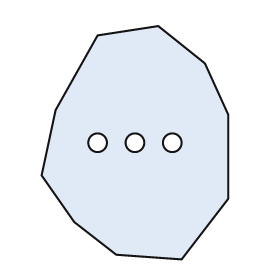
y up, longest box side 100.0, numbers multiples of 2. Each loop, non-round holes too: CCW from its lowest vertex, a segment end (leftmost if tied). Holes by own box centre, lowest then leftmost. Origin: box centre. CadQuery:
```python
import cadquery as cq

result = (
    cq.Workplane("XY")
    .moveTo(20.0, -50.0)
    .lineTo(40.0, -24.0)
    .lineTo(40.0, 12.0)
    .lineTo(30.0, 34.0)
    .lineTo(10.0, 50.0)
    .lineTo(-16.0, 46.0)
    .lineTo(-34.0, 14.0)
    .lineTo(-40.0, -14.0)
    .lineTo(-26.0, -34.0)
    .lineTo(-8.0, -48.0)
    .close()
    .moveTo(-16.0, 0.0)
    .circle(4.0)
    .moveTo(0.0, 0.0)
    .circle(4.0)
    .moveTo(16.0, 0.0)
    .circle(4.0)
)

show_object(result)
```